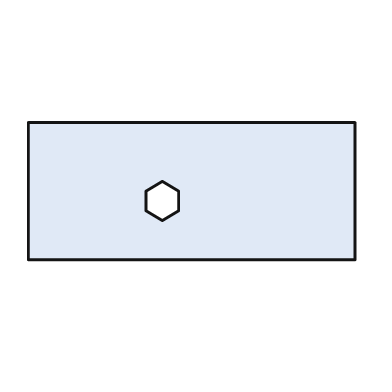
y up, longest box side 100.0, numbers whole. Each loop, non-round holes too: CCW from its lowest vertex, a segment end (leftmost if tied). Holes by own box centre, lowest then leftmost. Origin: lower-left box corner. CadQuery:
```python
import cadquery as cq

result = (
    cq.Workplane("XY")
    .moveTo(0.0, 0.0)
    .lineTo(100.0, 0.0)
    .lineTo(100.0, 42.0)
    .lineTo(0.0, 42.0)
    .close()
    .moveTo(41.0, 12.0)
    .lineTo(46.0, 15.0)
    .lineTo(46.0, 21.0)
    .lineTo(41.0, 24.0)
    .lineTo(36.0, 21.0)
    .lineTo(36.0, 15.0)
    .close()
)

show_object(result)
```